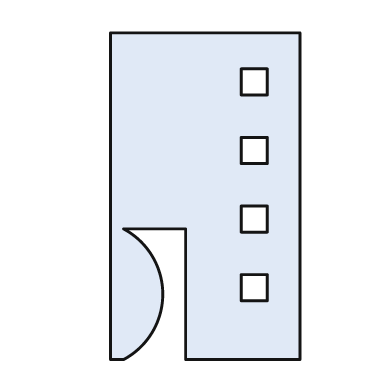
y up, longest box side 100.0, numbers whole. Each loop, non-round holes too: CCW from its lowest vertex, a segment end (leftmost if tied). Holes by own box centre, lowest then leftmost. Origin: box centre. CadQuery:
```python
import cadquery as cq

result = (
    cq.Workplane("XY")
    .moveTo(-29.0, -50.0)
    .lineTo(-25.0, -50.0)
    .threePointArc((-13.0, -30.0), (-25.0, -10.0))
    .lineTo(-6.0, -10.0)
    .lineTo(-6.0, -50.0)
    .lineTo(29.0, -50.0)
    .lineTo(29.0, 50.0)
    .lineTo(-29.0, 50.0)
    .close()
    .moveTo(11.0, -32.0)
    .lineTo(19.0, -32.0)
    .lineTo(19.0, -24.0)
    .lineTo(11.0, -24.0)
    .close()
    .moveTo(11.0, -11.0)
    .lineTo(19.0, -11.0)
    .lineTo(19.0, -3.0)
    .lineTo(11.0, -3.0)
    .close()
    .moveTo(11.0, 10.0)
    .lineTo(19.0, 10.0)
    .lineTo(19.0, 18.0)
    .lineTo(11.0, 18.0)
    .close()
    .moveTo(11.0, 31.0)
    .lineTo(19.0, 31.0)
    .lineTo(19.0, 39.0)
    .lineTo(11.0, 39.0)
    .close()
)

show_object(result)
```